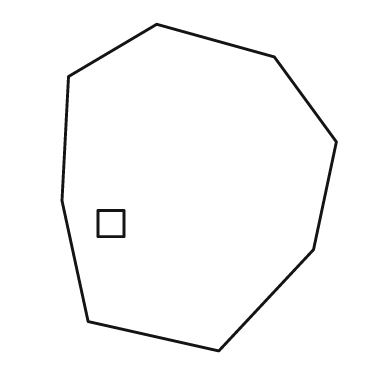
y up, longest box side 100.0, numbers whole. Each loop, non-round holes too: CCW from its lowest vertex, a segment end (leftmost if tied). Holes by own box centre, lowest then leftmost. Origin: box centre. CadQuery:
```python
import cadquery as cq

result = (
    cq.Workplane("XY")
    .moveTo(6.0, -50.0)
    .lineTo(35.0, -19.0)
    .lineTo(42.0, 14.0)
    .lineTo(23.0, 40.0)
    .lineTo(-13.0, 50.0)
    .lineTo(-40.0, 34.0)
    .lineTo(-42.0, -4.0)
    .lineTo(-34.0, -41.0)
    .close()
    .moveTo(-31.0, -15.0)
    .lineTo(-23.0, -15.0)
    .lineTo(-23.0, -7.0)
    .lineTo(-31.0, -7.0)
    .close()
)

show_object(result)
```